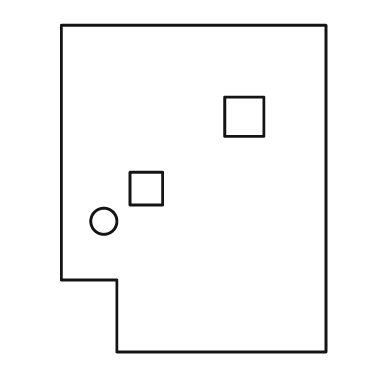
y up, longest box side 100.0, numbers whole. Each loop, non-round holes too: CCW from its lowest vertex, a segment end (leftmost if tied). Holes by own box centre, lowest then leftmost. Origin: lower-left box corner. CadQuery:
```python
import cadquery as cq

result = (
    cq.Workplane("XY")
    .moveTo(17.0, 0.0)
    .lineTo(81.0, 0.0)
    .lineTo(81.0, 100.0)
    .lineTo(0.0, 100.0)
    .lineTo(0.0, 22.0)
    .lineTo(17.0, 22.0)
    .close()
    .moveTo(13.0, 40.0)
    .circle(4.0)
    .moveTo(21.0, 45.0)
    .lineTo(31.0, 45.0)
    .lineTo(31.0, 55.0)
    .lineTo(21.0, 55.0)
    .close()
    .moveTo(50.0, 66.0)
    .lineTo(62.0, 66.0)
    .lineTo(62.0, 78.0)
    .lineTo(50.0, 78.0)
    .close()
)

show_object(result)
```